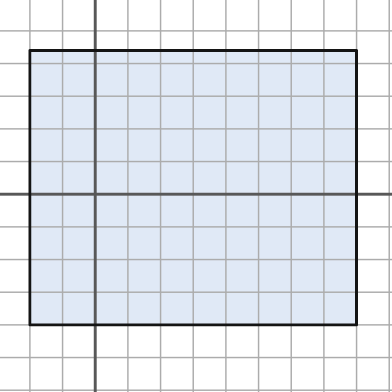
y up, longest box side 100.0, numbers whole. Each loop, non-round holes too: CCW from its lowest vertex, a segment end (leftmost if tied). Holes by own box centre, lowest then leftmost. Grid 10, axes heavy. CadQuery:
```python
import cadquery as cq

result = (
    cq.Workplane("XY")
    .moveTo(-20.0, -40.0)
    .lineTo(80.0, -40.0)
    .lineTo(80.0, 44.0)
    .lineTo(-20.0, 44.0)
    .close()
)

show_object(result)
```